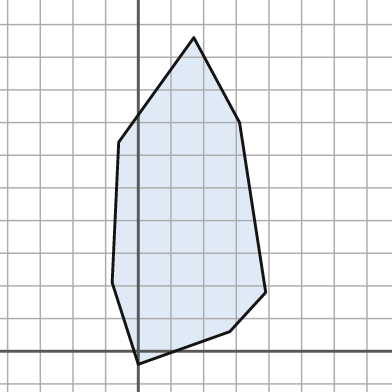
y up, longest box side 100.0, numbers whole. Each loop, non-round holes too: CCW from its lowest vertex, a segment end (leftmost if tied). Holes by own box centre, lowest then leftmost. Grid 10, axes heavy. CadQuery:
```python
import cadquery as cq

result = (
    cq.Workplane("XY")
    .moveTo(0.0, -4.0)
    .lineTo(28.0, 6.0)
    .lineTo(39.0, 18.0)
    .lineTo(31.0, 70.0)
    .lineTo(17.0, 96.0)
    .lineTo(-6.0, 64.0)
    .lineTo(-8.0, 21.0)
    .close()
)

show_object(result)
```